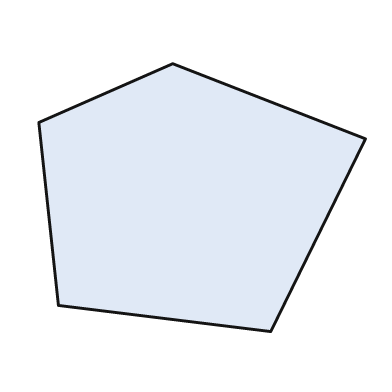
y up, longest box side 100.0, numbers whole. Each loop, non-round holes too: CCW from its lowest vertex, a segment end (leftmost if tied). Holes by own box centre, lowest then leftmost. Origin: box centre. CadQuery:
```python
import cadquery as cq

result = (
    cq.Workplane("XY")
    .moveTo(21.0, -41.0)
    .lineTo(50.0, 18.0)
    .lineTo(-9.0, 41.0)
    .lineTo(-50.0, 23.0)
    .lineTo(-44.0, -33.0)
    .close()
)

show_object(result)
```